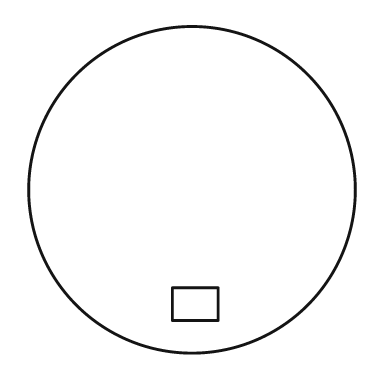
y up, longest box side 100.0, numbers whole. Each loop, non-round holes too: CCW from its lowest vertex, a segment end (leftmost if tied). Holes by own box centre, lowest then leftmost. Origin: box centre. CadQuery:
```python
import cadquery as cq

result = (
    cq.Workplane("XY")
    .moveTo(0.0, 0.0)
    .circle(50.0)
    .moveTo(-6.0, -40.0)
    .lineTo(8.0, -40.0)
    .lineTo(8.0, -30.0)
    .lineTo(-6.0, -30.0)
    .close()
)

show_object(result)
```